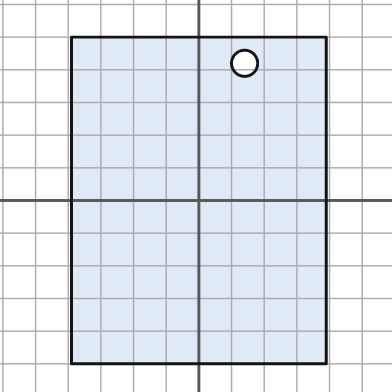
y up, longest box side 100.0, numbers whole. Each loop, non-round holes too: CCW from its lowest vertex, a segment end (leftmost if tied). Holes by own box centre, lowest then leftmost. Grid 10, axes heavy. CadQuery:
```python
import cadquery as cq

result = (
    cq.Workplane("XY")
    .moveTo(-39.0, -50.0)
    .lineTo(39.0, -50.0)
    .lineTo(39.0, 50.0)
    .lineTo(-39.0, 50.0)
    .close()
    .moveTo(14.0, 42.0)
    .circle(4.0)
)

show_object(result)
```